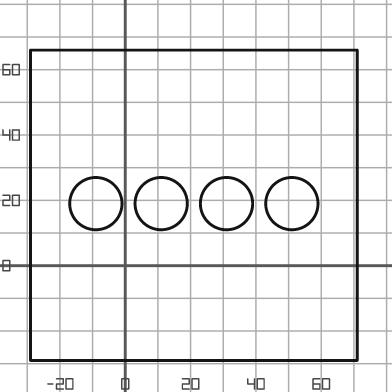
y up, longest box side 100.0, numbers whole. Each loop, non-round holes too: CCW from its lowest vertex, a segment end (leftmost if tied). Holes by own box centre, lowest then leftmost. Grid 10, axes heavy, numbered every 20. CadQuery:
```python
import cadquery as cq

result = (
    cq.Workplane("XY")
    .moveTo(-29.0, -29.0)
    .lineTo(71.0, -29.0)
    .lineTo(71.0, 66.0)
    .lineTo(-29.0, 66.0)
    .close()
    .moveTo(-9.0, 19.0)
    .circle(8.0)
    .moveTo(11.0, 19.0)
    .circle(8.0)
    .moveTo(31.0, 19.0)
    .circle(8.0)
    .moveTo(51.0, 19.0)
    .circle(8.0)
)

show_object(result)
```